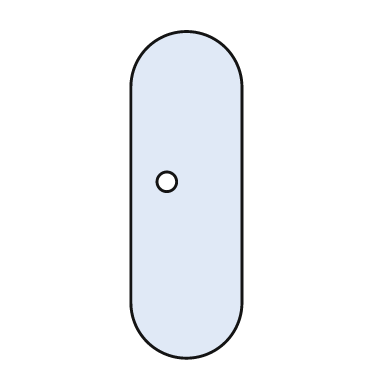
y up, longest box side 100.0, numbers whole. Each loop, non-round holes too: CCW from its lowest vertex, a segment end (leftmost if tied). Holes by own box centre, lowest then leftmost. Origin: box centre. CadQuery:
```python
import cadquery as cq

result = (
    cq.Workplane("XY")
    .moveTo(-17.0, -33.0)
    .threePointArc((0.0, -50.0), (17.0, -33.0))
    .lineTo(17.0, 33.0)
    .threePointArc((0.0, 50.0), (-17.0, 33.0))
    .close()
    .moveTo(-6.0, 4.0)
    .circle(3.0)
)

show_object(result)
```